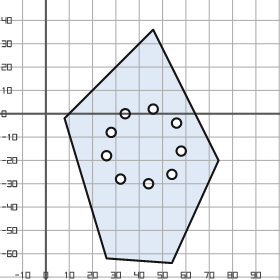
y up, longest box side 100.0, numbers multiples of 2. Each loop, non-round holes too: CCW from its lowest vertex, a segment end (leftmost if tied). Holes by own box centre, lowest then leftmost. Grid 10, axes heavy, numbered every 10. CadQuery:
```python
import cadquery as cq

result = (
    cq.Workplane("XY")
    .moveTo(54.0, -64.0)
    .lineTo(74.0, -20.0)
    .lineTo(46.0, 36.0)
    .lineTo(8.0, -2.0)
    .lineTo(26.0, -62.0)
    .close()
    .moveTo(44.0, -30.0)
    .circle(2.0)
    .moveTo(32.0, -28.0)
    .circle(2.0)
    .moveTo(54.0, -26.0)
    .circle(2.0)
    .moveTo(26.0, -18.0)
    .circle(2.0)
    .moveTo(58.0, -16.0)
    .circle(2.0)
    .moveTo(28.0, -8.0)
    .circle(2.0)
    .moveTo(56.0, -4.0)
    .circle(2.0)
    .moveTo(34.0, 0.0)
    .circle(2.0)
    .moveTo(46.0, 2.0)
    .circle(2.0)
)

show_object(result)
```